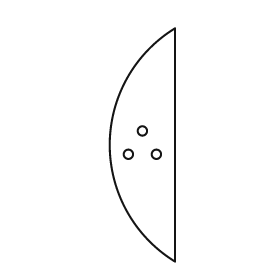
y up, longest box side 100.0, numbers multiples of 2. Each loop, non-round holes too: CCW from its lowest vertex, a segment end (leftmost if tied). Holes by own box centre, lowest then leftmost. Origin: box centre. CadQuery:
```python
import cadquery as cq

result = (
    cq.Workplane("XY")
    .moveTo(14.0, -50.0)
    .lineTo(14.0, 50.0)
    .threePointArc((-14.0, 0.0), (14.0, -50.0))
    .close()
    .moveTo(-6.0, -4.0)
    .circle(2.0)
    .moveTo(6.0, -4.0)
    .circle(2.0)
    .moveTo(0.0, 6.0)
    .circle(2.0)
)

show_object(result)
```